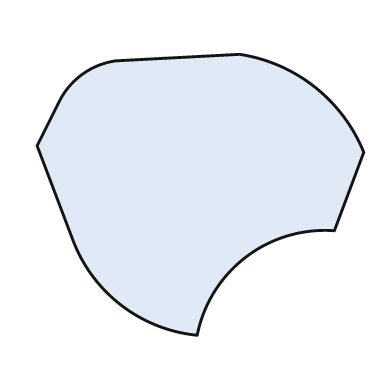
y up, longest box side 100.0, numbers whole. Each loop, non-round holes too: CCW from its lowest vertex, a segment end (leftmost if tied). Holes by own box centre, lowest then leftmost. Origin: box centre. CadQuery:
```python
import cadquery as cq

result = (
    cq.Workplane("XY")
    .moveTo(-1.0, -43.0)
    .threePointArc((14.0, -19.0), (41.0, -11.0))
    .lineTo(50.0, 13.0)
    .threePointArc((35.0, 33.0), (12.0, 43.0))
    .lineTo(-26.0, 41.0)
    .threePointArc((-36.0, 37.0), (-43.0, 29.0))
    .lineTo(-50.0, 15.0)
    .lineTo(-39.0, -14.0)
    .threePointArc((-24.0, -34.0), (-1.0, -43.0))
    .close()
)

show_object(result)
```